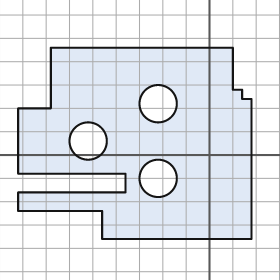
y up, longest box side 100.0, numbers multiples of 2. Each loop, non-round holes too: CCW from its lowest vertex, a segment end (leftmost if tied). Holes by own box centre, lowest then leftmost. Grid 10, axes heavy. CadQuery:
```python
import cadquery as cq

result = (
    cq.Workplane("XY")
    .moveTo(-46.0, -36.0)
    .lineTo(18.0, -36.0)
    .lineTo(18.0, 24.0)
    .lineTo(14.0, 24.0)
    .lineTo(14.0, 28.0)
    .lineTo(10.0, 28.0)
    .lineTo(10.0, 46.0)
    .lineTo(-68.0, 46.0)
    .lineTo(-68.0, 20.0)
    .lineTo(-82.0, 20.0)
    .lineTo(-82.0, -8.0)
    .lineTo(-36.0, -8.0)
    .lineTo(-36.0, -16.0)
    .lineTo(-82.0, -16.0)
    .lineTo(-82.0, -24.0)
    .lineTo(-46.0, -24.0)
    .close()
    .moveTo(-22.0, -10.0)
    .circle(8.0)
    .moveTo(-52.0, 6.0)
    .circle(8.0)
    .moveTo(-22.0, 22.0)
    .circle(8.0)
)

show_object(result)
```